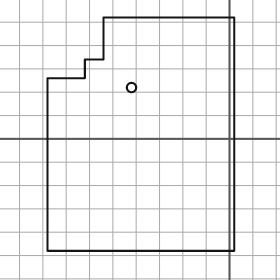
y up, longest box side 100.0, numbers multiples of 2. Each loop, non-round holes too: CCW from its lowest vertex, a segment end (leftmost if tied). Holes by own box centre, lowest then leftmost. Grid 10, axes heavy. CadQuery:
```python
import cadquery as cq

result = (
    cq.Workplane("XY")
    .moveTo(-78.0, -48.0)
    .lineTo(2.0, -48.0)
    .lineTo(2.0, 52.0)
    .lineTo(-54.0, 52.0)
    .lineTo(-54.0, 34.0)
    .lineTo(-62.0, 34.0)
    .lineTo(-62.0, 26.0)
    .lineTo(-78.0, 26.0)
    .close()
    .moveTo(-42.0, 22.0)
    .circle(2.0)
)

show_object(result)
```